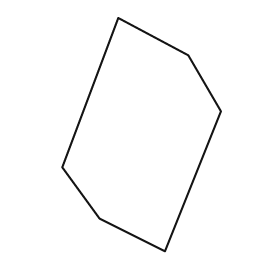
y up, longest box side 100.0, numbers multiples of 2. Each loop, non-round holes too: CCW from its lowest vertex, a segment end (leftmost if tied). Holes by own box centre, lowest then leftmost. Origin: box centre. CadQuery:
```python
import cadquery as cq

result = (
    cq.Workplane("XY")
    .moveTo(10.0, -50.0)
    .lineTo(34.0, 10.0)
    .lineTo(20.0, 34.0)
    .lineTo(-10.0, 50.0)
    .lineTo(-34.0, -14.0)
    .lineTo(-18.0, -36.0)
    .close()
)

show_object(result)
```